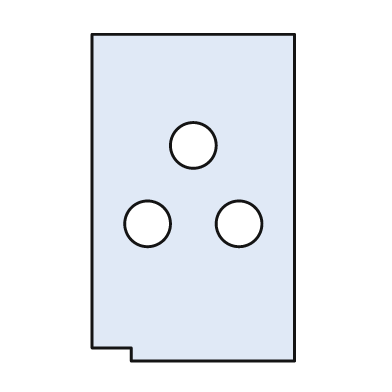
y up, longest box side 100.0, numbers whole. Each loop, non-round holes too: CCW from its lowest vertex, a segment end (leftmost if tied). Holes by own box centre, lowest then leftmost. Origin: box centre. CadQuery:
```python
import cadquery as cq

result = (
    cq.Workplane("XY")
    .moveTo(-19.0, -50.0)
    .lineTo(31.0, -50.0)
    .lineTo(31.0, 50.0)
    .lineTo(-31.0, 50.0)
    .lineTo(-31.0, -46.0)
    .lineTo(-19.0, -46.0)
    .close()
    .moveTo(-14.0, -8.0)
    .circle(7.0)
    .moveTo(14.0, -8.0)
    .circle(7.0)
    .moveTo(0.0, 16.0)
    .circle(7.0)
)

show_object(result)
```